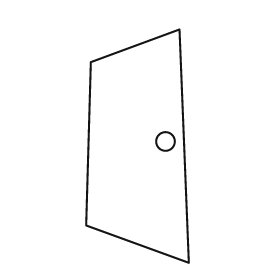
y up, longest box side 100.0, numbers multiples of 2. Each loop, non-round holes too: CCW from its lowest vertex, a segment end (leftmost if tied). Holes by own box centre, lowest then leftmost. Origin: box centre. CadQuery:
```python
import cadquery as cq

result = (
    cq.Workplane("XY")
    .moveTo(22.0, -50.0)
    .lineTo(18.0, 50.0)
    .lineTo(-20.0, 36.0)
    .lineTo(-22.0, -34.0)
    .close()
    .moveTo(12.0, 2.0)
    .circle(4.0)
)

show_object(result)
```